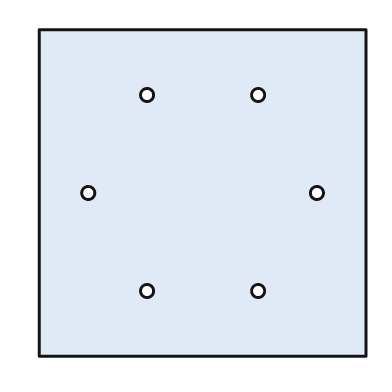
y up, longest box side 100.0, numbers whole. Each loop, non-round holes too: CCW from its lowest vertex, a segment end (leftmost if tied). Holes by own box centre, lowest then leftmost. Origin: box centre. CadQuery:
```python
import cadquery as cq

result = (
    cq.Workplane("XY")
    .moveTo(-50.0, -50.0)
    .lineTo(50.0, -50.0)
    .lineTo(50.0, 50.0)
    .lineTo(-50.0, 50.0)
    .close()
    .moveTo(-17.0, -30.0)
    .circle(2.0)
    .moveTo(17.0, -30.0)
    .circle(2.0)
    .moveTo(-35.0, 0.0)
    .circle(2.0)
    .moveTo(35.0, 0.0)
    .circle(2.0)
    .moveTo(-17.0, 30.0)
    .circle(2.0)
    .moveTo(17.0, 30.0)
    .circle(2.0)
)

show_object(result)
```